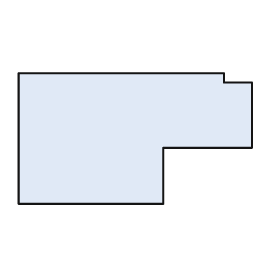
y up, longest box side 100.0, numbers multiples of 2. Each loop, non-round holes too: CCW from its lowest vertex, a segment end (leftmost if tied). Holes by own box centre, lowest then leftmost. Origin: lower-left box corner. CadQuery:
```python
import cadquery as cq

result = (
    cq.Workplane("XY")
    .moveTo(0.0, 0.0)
    .lineTo(62.0, 0.0)
    .lineTo(62.0, 24.0)
    .lineTo(100.0, 24.0)
    .lineTo(100.0, 52.0)
    .lineTo(88.0, 52.0)
    .lineTo(88.0, 56.0)
    .lineTo(0.0, 56.0)
    .close()
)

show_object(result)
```